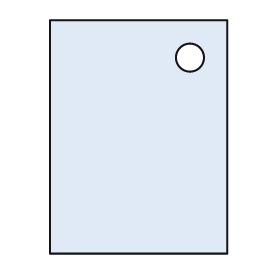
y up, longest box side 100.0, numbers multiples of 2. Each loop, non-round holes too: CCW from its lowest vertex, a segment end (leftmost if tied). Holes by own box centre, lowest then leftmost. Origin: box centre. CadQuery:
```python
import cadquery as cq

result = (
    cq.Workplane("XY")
    .moveTo(-38.0, -50.0)
    .lineTo(38.0, -50.0)
    .lineTo(38.0, 50.0)
    .lineTo(-38.0, 50.0)
    .close()
    .moveTo(22.0, 34.0)
    .circle(6.0)
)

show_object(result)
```